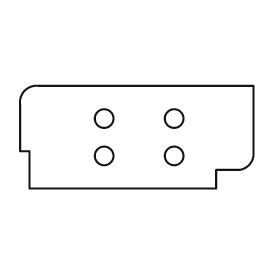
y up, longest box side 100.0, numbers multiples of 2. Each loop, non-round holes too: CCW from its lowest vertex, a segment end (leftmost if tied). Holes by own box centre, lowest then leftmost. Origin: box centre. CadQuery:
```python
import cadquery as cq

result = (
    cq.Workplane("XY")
    .moveTo(-46.0, -22.0)
    .lineTo(34.0, -22.0)
    .lineTo(34.0, -14.0)
    .lineTo(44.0, -14.0)
    .threePointArc((48.0, -12.0), (50.0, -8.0))
    .lineTo(50.0, 22.0)
    .lineTo(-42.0, 22.0)
    .threePointArc((-48.0, 20.0), (-50.0, 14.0))
    .lineTo(-50.0, -6.0)
    .lineTo(-46.0, -6.0)
    .close()
    .moveTo(-14.0, -8.0)
    .circle(4.0)
    .moveTo(16.0, -8.0)
    .circle(4.0)
    .moveTo(-14.0, 8.0)
    .circle(4.0)
    .moveTo(16.0, 8.0)
    .circle(4.0)
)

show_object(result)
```